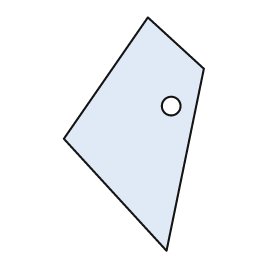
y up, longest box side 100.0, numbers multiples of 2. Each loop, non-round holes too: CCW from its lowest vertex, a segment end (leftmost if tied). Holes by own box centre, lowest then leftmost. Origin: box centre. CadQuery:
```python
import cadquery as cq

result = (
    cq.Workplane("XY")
    .moveTo(14.0, -50.0)
    .lineTo(30.0, 28.0)
    .lineTo(6.0, 50.0)
    .lineTo(-30.0, -2.0)
    .close()
    .moveTo(16.0, 12.0)
    .circle(4.0)
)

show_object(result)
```